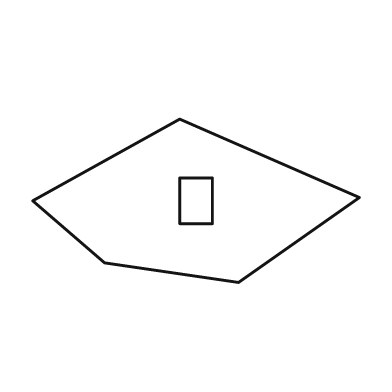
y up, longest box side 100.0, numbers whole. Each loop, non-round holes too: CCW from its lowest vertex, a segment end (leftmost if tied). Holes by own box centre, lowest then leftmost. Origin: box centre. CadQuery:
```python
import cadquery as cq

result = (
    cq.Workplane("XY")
    .moveTo(13.0, -25.0)
    .lineTo(50.0, 1.0)
    .lineTo(-5.0, 25.0)
    .lineTo(-50.0, 0.0)
    .lineTo(-28.0, -19.0)
    .close()
    .moveTo(-5.0, -7.0)
    .lineTo(5.0, -7.0)
    .lineTo(5.0, 7.0)
    .lineTo(-5.0, 7.0)
    .close()
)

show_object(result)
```